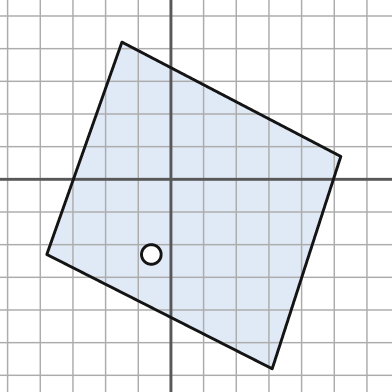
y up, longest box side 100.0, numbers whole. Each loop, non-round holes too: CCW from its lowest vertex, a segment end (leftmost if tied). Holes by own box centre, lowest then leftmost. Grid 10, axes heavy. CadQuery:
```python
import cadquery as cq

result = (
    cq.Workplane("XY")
    .moveTo(31.0, -58.0)
    .lineTo(52.0, 7.0)
    .lineTo(-15.0, 42.0)
    .lineTo(-38.0, -23.0)
    .close()
    .moveTo(-6.0, -23.0)
    .circle(3.0)
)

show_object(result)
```